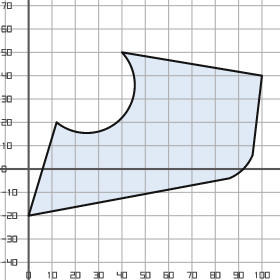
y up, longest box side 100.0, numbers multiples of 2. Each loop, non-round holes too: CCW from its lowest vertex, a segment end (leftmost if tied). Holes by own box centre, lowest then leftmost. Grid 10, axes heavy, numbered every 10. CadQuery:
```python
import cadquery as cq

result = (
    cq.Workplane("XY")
    .moveTo(0.0, -20.0)
    .lineTo(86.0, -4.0)
    .threePointArc((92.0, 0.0), (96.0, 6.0))
    .lineTo(100.0, 40.0)
    .lineTo(40.0, 50.0)
    .threePointArc((40.0, 22.0), (12.0, 20.0))
    .close()
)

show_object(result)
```